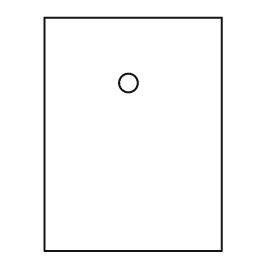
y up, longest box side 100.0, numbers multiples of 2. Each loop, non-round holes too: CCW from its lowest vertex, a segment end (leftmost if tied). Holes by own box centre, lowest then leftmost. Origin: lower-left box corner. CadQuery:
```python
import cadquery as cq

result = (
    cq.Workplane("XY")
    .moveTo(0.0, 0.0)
    .lineTo(76.0, 0.0)
    .lineTo(76.0, 100.0)
    .lineTo(0.0, 100.0)
    .close()
    .moveTo(36.0, 72.0)
    .circle(4.0)
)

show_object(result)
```